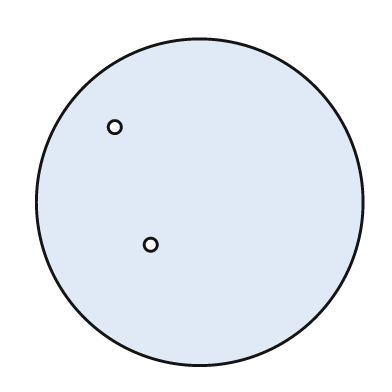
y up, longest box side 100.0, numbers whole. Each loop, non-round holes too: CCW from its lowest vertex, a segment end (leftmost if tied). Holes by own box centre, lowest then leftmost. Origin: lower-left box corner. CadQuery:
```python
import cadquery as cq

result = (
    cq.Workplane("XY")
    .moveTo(50.0, 50.0)
    .circle(50.0)
    .moveTo(35.0, 37.0)
    .circle(2.0)
    .moveTo(24.0, 73.0)
    .circle(2.0)
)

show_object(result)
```